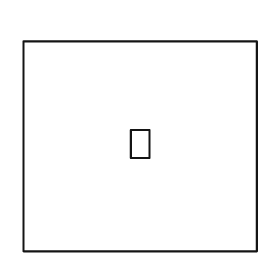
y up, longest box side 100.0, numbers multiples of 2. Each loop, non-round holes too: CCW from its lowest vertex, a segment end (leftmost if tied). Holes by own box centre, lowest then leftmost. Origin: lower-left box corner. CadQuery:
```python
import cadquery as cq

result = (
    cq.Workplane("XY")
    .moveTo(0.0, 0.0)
    .lineTo(100.0, 0.0)
    .lineTo(100.0, 90.0)
    .lineTo(0.0, 90.0)
    .close()
    .moveTo(46.0, 40.0)
    .lineTo(54.0, 40.0)
    .lineTo(54.0, 52.0)
    .lineTo(46.0, 52.0)
    .close()
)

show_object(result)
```